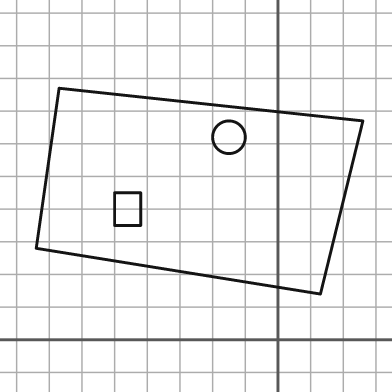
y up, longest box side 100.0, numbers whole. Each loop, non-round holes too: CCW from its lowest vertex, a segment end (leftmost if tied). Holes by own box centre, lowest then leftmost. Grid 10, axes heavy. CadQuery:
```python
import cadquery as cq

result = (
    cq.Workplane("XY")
    .moveTo(13.0, 14.0)
    .lineTo(26.0, 67.0)
    .lineTo(-67.0, 77.0)
    .lineTo(-74.0, 28.0)
    .close()
    .moveTo(-50.0, 35.0)
    .lineTo(-42.0, 35.0)
    .lineTo(-42.0, 45.0)
    .lineTo(-50.0, 45.0)
    .close()
    .moveTo(-15.0, 62.0)
    .circle(5.0)
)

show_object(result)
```